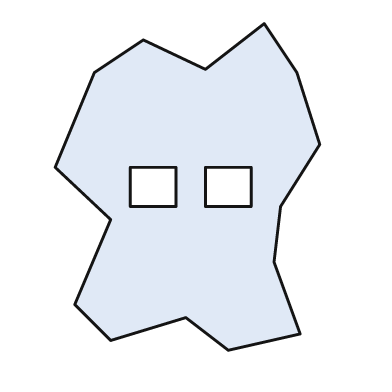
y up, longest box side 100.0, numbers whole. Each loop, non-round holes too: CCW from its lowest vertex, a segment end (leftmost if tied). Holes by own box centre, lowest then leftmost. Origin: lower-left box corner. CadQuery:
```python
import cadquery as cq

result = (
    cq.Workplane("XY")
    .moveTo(53.0, 0.0)
    .lineTo(75.0, 5.0)
    .lineTo(67.0, 27.0)
    .lineTo(69.0, 44.0)
    .lineTo(81.0, 63.0)
    .lineTo(74.0, 85.0)
    .lineTo(64.0, 100.0)
    .lineTo(46.0, 86.0)
    .lineTo(27.0, 95.0)
    .lineTo(12.0, 85.0)
    .lineTo(0.0, 56.0)
    .lineTo(17.0, 40.0)
    .lineTo(6.0, 14.0)
    .lineTo(17.0, 3.0)
    .lineTo(40.0, 10.0)
    .close()
    .moveTo(23.0, 44.0)
    .lineTo(37.0, 44.0)
    .lineTo(37.0, 56.0)
    .lineTo(23.0, 56.0)
    .close()
    .moveTo(46.0, 44.0)
    .lineTo(60.0, 44.0)
    .lineTo(60.0, 56.0)
    .lineTo(46.0, 56.0)
    .close()
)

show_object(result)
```